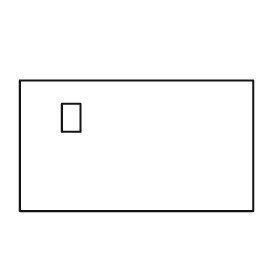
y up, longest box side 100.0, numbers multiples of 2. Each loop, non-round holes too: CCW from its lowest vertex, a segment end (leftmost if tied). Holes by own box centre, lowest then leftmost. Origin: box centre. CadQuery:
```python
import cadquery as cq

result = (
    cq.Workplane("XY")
    .moveTo(-50.0, -28.0)
    .lineTo(50.0, -28.0)
    .lineTo(50.0, 28.0)
    .lineTo(-50.0, 28.0)
    .close()
    .moveTo(-32.0, 6.0)
    .lineTo(-24.0, 6.0)
    .lineTo(-24.0, 18.0)
    .lineTo(-32.0, 18.0)
    .close()
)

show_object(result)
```